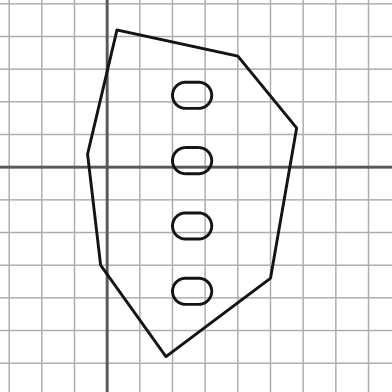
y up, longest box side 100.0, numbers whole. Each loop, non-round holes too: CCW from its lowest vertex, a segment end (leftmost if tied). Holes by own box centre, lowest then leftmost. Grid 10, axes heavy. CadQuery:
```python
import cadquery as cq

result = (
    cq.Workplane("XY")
    .moveTo(18.0, -58.0)
    .lineTo(50.0, -34.0)
    .lineTo(58.0, 12.0)
    .lineTo(40.0, 34.0)
    .lineTo(3.0, 42.0)
    .lineTo(-6.0, 4.0)
    .lineTo(-2.0, -30.0)
    .close()
    .moveTo(24.0, -42.0)
    .lineTo(28.0, -42.0)
    .threePointArc((32.0, -38.0), (28.0, -34.0))
    .lineTo(24.0, -34.0)
    .threePointArc((20.0, -38.0), (24.0, -42.0))
    .close()
    .moveTo(24.0, -22.0)
    .lineTo(28.0, -22.0)
    .threePointArc((32.0, -18.0), (28.0, -14.0))
    .lineTo(24.0, -14.0)
    .threePointArc((20.0, -18.0), (24.0, -22.0))
    .close()
    .moveTo(24.0, -2.0)
    .lineTo(28.0, -2.0)
    .threePointArc((32.0, 2.0), (28.0, 6.0))
    .lineTo(24.0, 6.0)
    .threePointArc((20.0, 2.0), (24.0, -2.0))
    .close()
    .moveTo(24.0, 18.0)
    .lineTo(28.0, 18.0)
    .threePointArc((32.0, 22.0), (28.0, 26.0))
    .lineTo(24.0, 26.0)
    .threePointArc((20.0, 22.0), (24.0, 18.0))
    .close()
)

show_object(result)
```